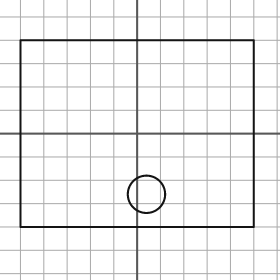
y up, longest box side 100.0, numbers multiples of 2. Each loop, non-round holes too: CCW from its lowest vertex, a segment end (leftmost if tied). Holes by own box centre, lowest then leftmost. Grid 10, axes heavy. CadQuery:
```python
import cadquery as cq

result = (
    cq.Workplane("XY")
    .moveTo(-50.0, -40.0)
    .lineTo(50.0, -40.0)
    .lineTo(50.0, 40.0)
    .lineTo(-50.0, 40.0)
    .close()
    .moveTo(4.0, -26.0)
    .circle(8.0)
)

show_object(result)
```